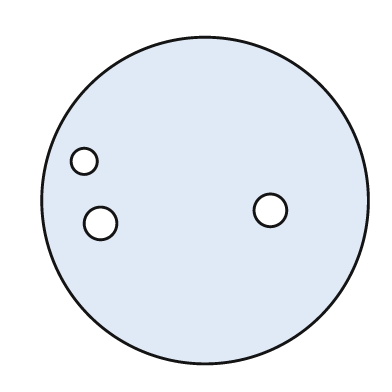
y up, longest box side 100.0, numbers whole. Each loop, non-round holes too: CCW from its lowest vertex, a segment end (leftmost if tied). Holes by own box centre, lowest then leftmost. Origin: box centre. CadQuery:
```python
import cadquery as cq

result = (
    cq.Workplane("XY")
    .moveTo(0.0, 0.0)
    .circle(50.0)
    .moveTo(-32.0, -7.0)
    .circle(5.0)
    .moveTo(20.0, -3.0)
    .circle(5.0)
    .moveTo(-37.0, 12.0)
    .circle(4.0)
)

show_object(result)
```